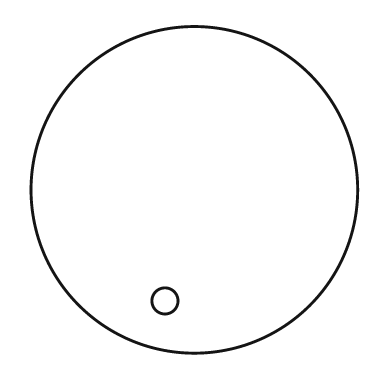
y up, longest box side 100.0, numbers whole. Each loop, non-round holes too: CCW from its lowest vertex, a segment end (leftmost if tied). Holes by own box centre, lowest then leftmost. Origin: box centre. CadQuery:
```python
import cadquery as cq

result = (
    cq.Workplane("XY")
    .moveTo(0.0, 0.0)
    .circle(50.0)
    .moveTo(-9.0, -34.0)
    .circle(4.0)
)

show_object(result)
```